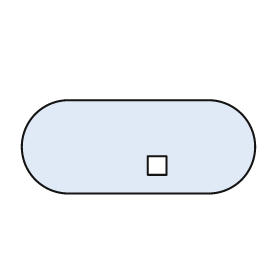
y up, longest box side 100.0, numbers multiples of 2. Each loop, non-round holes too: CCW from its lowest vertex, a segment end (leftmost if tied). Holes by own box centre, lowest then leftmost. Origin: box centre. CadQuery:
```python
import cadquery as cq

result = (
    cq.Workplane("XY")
    .moveTo(-30.0, -20.0)
    .lineTo(30.0, -20.0)
    .threePointArc((50.0, 0.0), (30.0, 20.0))
    .lineTo(-30.0, 20.0)
    .threePointArc((-50.0, 0.0), (-30.0, -20.0))
    .close()
    .moveTo(4.0, -12.0)
    .lineTo(12.0, -12.0)
    .lineTo(12.0, -4.0)
    .lineTo(4.0, -4.0)
    .close()
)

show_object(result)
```